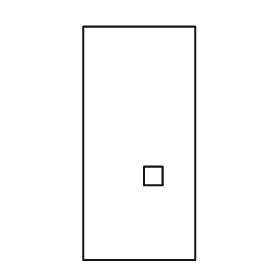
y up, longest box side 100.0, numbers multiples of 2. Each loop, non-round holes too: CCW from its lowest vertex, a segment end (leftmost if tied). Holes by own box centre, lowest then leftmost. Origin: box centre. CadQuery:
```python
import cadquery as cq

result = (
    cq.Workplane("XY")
    .moveTo(-24.0, -50.0)
    .lineTo(24.0, -50.0)
    .lineTo(24.0, 50.0)
    .lineTo(-24.0, 50.0)
    .close()
    .moveTo(2.0, -18.0)
    .lineTo(10.0, -18.0)
    .lineTo(10.0, -10.0)
    .lineTo(2.0, -10.0)
    .close()
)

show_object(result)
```